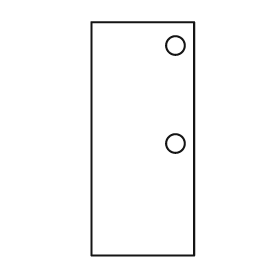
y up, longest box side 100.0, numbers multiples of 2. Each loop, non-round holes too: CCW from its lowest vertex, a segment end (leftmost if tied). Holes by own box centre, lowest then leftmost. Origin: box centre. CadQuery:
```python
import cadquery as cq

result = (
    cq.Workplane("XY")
    .moveTo(-22.0, -50.0)
    .lineTo(22.0, -50.0)
    .lineTo(22.0, 50.0)
    .lineTo(-22.0, 50.0)
    .close()
    .moveTo(14.0, -2.0)
    .circle(4.0)
    .moveTo(14.0, 40.0)
    .circle(4.0)
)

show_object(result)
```